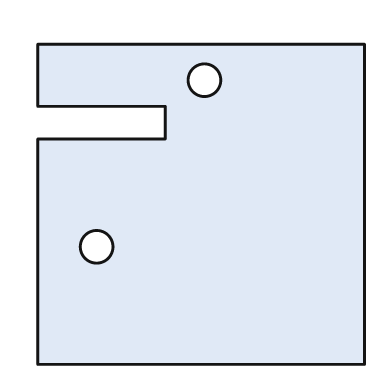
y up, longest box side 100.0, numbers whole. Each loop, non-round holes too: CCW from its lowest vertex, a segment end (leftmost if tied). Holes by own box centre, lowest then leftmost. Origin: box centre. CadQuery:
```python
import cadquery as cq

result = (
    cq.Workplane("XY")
    .moveTo(-50.0, -49.0)
    .lineTo(50.0, -49.0)
    .lineTo(50.0, 49.0)
    .lineTo(-50.0, 49.0)
    .lineTo(-50.0, 30.0)
    .lineTo(-11.0, 30.0)
    .lineTo(-11.0, 20.0)
    .lineTo(-50.0, 20.0)
    .close()
    .moveTo(-32.0, -13.0)
    .circle(5.0)
    .moveTo(1.0, 38.0)
    .circle(5.0)
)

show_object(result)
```